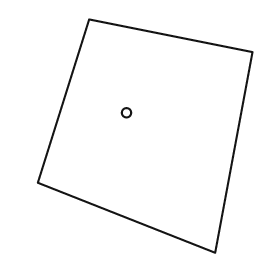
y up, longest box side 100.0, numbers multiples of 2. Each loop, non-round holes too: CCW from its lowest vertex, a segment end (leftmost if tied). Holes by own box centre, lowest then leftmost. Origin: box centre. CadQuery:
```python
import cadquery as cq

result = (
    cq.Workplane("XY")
    .moveTo(30.0, -50.0)
    .lineTo(46.0, 36.0)
    .lineTo(-24.0, 50.0)
    .lineTo(-46.0, -20.0)
    .close()
    .moveTo(-8.0, 10.0)
    .circle(2.0)
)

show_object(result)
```